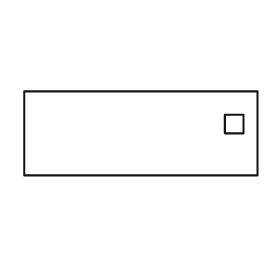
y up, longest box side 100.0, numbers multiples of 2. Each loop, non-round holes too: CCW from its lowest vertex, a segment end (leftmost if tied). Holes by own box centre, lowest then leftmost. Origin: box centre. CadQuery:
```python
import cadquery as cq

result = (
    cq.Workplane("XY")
    .moveTo(-50.0, -18.0)
    .lineTo(50.0, -18.0)
    .lineTo(50.0, 18.0)
    .lineTo(-50.0, 18.0)
    .close()
    .moveTo(36.0, 0.0)
    .lineTo(44.0, 0.0)
    .lineTo(44.0, 8.0)
    .lineTo(36.0, 8.0)
    .close()
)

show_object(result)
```